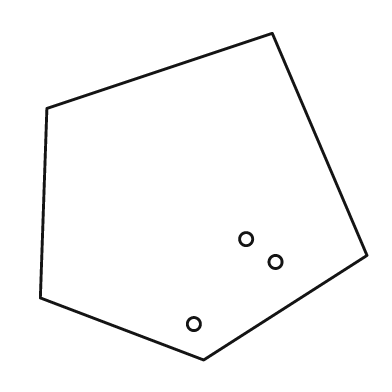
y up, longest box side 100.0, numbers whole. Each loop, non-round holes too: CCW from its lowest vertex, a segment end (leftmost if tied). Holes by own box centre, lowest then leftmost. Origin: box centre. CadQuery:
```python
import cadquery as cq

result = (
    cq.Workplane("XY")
    .moveTo(0.0, -50.0)
    .lineTo(50.0, -18.0)
    .lineTo(21.0, 50.0)
    .lineTo(-48.0, 27.0)
    .lineTo(-50.0, -31.0)
    .close()
    .moveTo(-3.0, -39.0)
    .circle(2.0)
    .moveTo(22.0, -20.0)
    .circle(2.0)
    .moveTo(13.0, -13.0)
    .circle(2.0)
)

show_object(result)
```